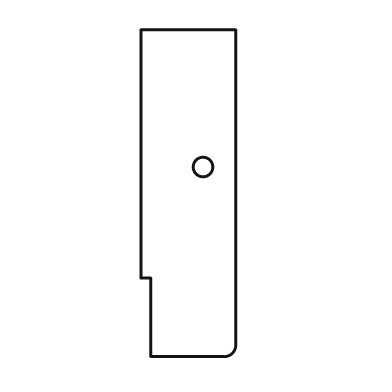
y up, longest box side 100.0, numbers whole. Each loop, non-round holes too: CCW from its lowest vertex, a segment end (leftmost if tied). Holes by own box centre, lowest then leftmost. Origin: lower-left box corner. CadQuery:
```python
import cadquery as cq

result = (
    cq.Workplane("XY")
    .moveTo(3.0, 0.0)
    .lineTo(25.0, 0.0)
    .threePointArc((28.0, 1.0), (29.0, 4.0))
    .lineTo(29.0, 100.0)
    .lineTo(0.0, 100.0)
    .lineTo(0.0, 24.0)
    .lineTo(3.0, 24.0)
    .close()
    .moveTo(19.0, 58.0)
    .circle(3.0)
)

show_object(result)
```